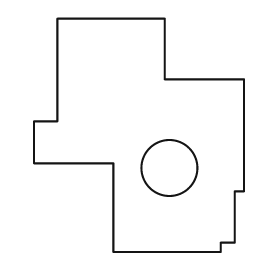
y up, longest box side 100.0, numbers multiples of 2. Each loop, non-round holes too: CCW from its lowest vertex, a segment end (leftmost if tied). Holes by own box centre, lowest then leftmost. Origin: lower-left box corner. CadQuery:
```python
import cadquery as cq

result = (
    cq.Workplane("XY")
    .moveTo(34.0, 0.0)
    .lineTo(80.0, 0.0)
    .lineTo(80.0, 4.0)
    .lineTo(86.0, 4.0)
    .lineTo(86.0, 26.0)
    .lineTo(90.0, 26.0)
    .lineTo(90.0, 74.0)
    .lineTo(56.0, 74.0)
    .lineTo(56.0, 100.0)
    .lineTo(10.0, 100.0)
    .lineTo(10.0, 56.0)
    .lineTo(0.0, 56.0)
    .lineTo(0.0, 38.0)
    .lineTo(34.0, 38.0)
    .close()
    .moveTo(58.0, 36.0)
    .circle(12.0)
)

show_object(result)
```